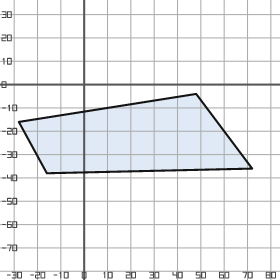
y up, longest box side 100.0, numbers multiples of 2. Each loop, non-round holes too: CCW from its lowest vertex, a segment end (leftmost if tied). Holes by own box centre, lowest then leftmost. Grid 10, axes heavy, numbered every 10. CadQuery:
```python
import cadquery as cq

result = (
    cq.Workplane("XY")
    .moveTo(-16.0, -38.0)
    .lineTo(72.0, -36.0)
    .lineTo(48.0, -4.0)
    .lineTo(-28.0, -16.0)
    .close()
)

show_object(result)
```